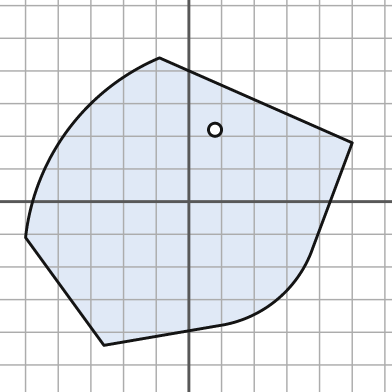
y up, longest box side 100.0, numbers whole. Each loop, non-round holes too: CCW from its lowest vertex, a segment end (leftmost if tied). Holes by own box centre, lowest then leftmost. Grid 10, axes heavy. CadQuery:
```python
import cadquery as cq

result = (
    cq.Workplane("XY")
    .moveTo(-26.0, -44.0)
    .lineTo(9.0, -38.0)
    .threePointArc((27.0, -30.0), (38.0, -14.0))
    .lineTo(50.0, 18.0)
    .lineTo(-9.0, 44.0)
    .threePointArc((-37.0, 22.0), (-50.0, -11.0))
    .close()
    .moveTo(8.0, 22.0)
    .circle(2.0)
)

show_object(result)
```